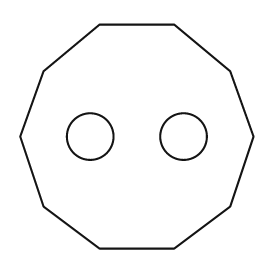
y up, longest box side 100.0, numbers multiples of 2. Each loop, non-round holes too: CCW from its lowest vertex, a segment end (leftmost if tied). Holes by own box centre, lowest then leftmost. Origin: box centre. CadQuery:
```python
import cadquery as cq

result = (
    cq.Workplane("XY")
    .moveTo(-16.0, -48.0)
    .lineTo(16.0, -48.0)
    .lineTo(40.0, -30.0)
    .lineTo(50.0, 0.0)
    .lineTo(40.0, 28.0)
    .lineTo(16.0, 48.0)
    .lineTo(-16.0, 48.0)
    .lineTo(-40.0, 28.0)
    .lineTo(-50.0, 0.0)
    .lineTo(-40.0, -30.0)
    .close()
    .moveTo(-20.0, 0.0)
    .circle(10.0)
    .moveTo(20.0, 0.0)
    .circle(10.0)
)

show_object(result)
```